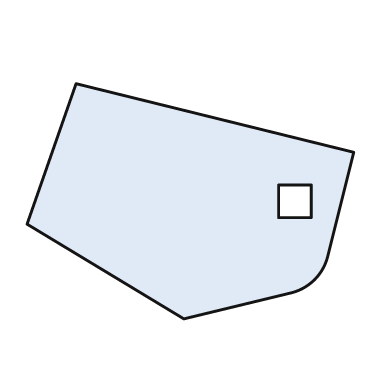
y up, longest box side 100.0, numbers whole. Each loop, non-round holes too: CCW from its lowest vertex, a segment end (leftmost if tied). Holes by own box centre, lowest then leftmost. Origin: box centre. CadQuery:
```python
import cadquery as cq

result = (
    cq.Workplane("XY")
    .moveTo(-2.0, -36.0)
    .lineTo(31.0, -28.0)
    .threePointArc((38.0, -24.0), (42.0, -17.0))
    .lineTo(50.0, 15.0)
    .lineTo(-35.0, 36.0)
    .lineTo(-50.0, -7.0)
    .close()
    .moveTo(27.0, -5.0)
    .lineTo(37.0, -5.0)
    .lineTo(37.0, 5.0)
    .lineTo(27.0, 5.0)
    .close()
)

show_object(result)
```